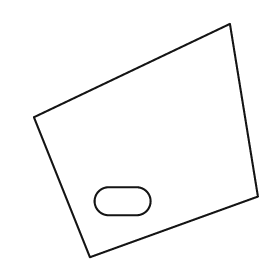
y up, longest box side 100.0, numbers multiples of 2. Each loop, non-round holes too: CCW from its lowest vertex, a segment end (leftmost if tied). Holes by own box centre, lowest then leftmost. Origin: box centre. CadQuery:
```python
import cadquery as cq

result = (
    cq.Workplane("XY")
    .moveTo(-24.0, -50.0)
    .lineTo(48.0, -24.0)
    .lineTo(36.0, 50.0)
    .lineTo(-48.0, 10.0)
    .close()
    .moveTo(-16.0, -32.0)
    .lineTo(-4.0, -32.0)
    .threePointArc((2.0, -26.0), (-4.0, -20.0))
    .lineTo(-16.0, -20.0)
    .threePointArc((-22.0, -26.0), (-16.0, -32.0))
    .close()
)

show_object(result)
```